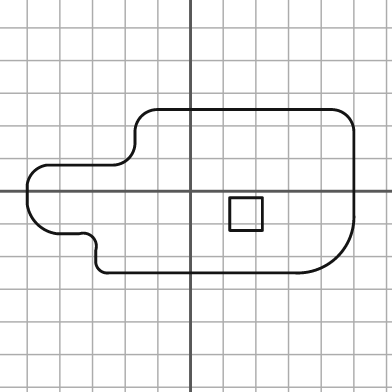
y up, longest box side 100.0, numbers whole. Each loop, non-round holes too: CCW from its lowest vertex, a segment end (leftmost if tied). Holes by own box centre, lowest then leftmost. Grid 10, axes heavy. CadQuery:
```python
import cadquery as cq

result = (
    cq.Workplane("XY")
    .moveTo(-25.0, -25.0)
    .lineTo(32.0, -25.0)
    .threePointArc((45.0, -20.0), (50.0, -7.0))
    .lineTo(50.0, 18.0)
    .threePointArc((48.0, 23.0), (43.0, 25.0))
    .lineTo(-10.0, 25.0)
    .threePointArc((-15.0, 23.0), (-17.0, 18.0))
    .lineTo(-17.0, 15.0)
    .threePointArc((-19.0, 10.0), (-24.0, 8.0))
    .lineTo(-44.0, 8.0)
    .threePointArc((-48.0, 6.0), (-50.0, 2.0))
    .lineTo(-50.0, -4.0)
    .threePointArc((-47.0, -10.0), (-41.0, -13.0))
    .lineTo(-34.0, -13.0)
    .threePointArc((-30.0, -14.0), (-29.0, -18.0))
    .lineTo(-29.0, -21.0)
    .threePointArc((-28.0, -24.0), (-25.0, -25.0))
    .close()
    .moveTo(12.0, -12.0)
    .lineTo(22.0, -12.0)
    .lineTo(22.0, -2.0)
    .lineTo(12.0, -2.0)
    .close()
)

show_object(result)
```